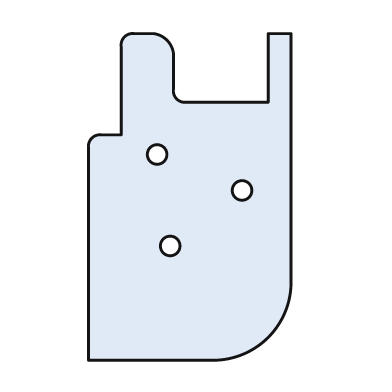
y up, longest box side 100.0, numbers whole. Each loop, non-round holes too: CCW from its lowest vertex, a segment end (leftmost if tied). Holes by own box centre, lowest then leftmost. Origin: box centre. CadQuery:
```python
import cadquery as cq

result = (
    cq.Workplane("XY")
    .moveTo(-31.0, -50.0)
    .lineTo(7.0, -50.0)
    .threePointArc((24.0, -43.0), (31.0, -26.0))
    .lineTo(31.0, 50.0)
    .lineTo(24.0, 50.0)
    .lineTo(24.0, 29.0)
    .lineTo(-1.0, 29.0)
    .threePointArc((-4.0, 30.0), (-5.0, 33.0))
    .lineTo(-5.0, 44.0)
    .threePointArc((-7.0, 48.0), (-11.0, 50.0))
    .lineTo(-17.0, 50.0)
    .threePointArc((-20.0, 49.0), (-21.0, 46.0))
    .lineTo(-21.0, 19.0)
    .lineTo(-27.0, 19.0)
    .threePointArc((-30.0, 18.0), (-31.0, 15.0))
    .close()
    .moveTo(-6.0, -15.0)
    .circle(3.0)
    .moveTo(16.0, 2.0)
    .circle(3.0)
    .moveTo(-10.0, 13.0)
    .circle(3.0)
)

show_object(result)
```